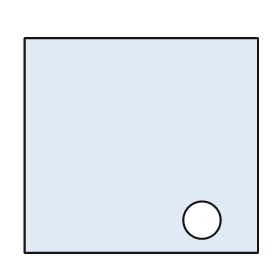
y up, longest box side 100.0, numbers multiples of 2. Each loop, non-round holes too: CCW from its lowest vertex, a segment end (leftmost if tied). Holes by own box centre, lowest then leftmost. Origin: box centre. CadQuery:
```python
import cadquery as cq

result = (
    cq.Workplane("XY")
    .moveTo(-50.0, -46.0)
    .lineTo(50.0, -46.0)
    .lineTo(50.0, 46.0)
    .lineTo(-50.0, 46.0)
    .close()
    .moveTo(26.0, -32.0)
    .circle(8.0)
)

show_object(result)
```